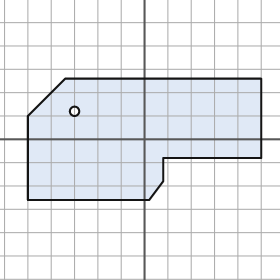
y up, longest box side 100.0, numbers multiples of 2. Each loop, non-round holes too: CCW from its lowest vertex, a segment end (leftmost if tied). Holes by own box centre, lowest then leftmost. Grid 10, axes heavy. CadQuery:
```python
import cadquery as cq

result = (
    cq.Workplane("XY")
    .moveTo(-50.0, -26.0)
    .lineTo(2.0, -26.0)
    .lineTo(8.0, -18.0)
    .lineTo(8.0, -8.0)
    .lineTo(50.0, -8.0)
    .lineTo(50.0, 26.0)
    .lineTo(-34.0, 26.0)
    .lineTo(-50.0, 10.0)
    .close()
    .moveTo(-30.0, 12.0)
    .circle(2.0)
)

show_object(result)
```